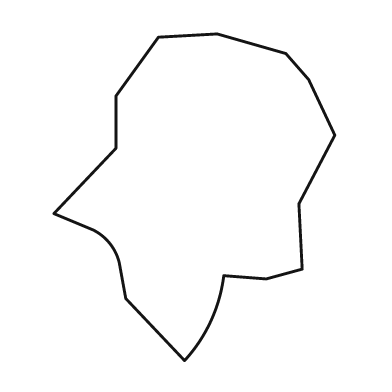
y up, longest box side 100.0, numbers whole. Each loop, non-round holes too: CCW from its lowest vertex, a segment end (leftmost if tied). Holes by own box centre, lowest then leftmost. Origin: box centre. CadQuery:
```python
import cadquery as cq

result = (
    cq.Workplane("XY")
    .moveTo(-3.0, -50.0)
    .threePointArc((5.0, -38.0), (9.0, -24.0))
    .lineTo(22.0, -25.0)
    .lineTo(33.0, -22.0)
    .lineTo(32.0, -2.0)
    .lineTo(43.0, 19.0)
    .lineTo(35.0, 36.0)
    .lineTo(28.0, 44.0)
    .lineTo(7.0, 50.0)
    .lineTo(-11.0, 49.0)
    .lineTo(-24.0, 31.0)
    .lineTo(-24.0, 15.0)
    .lineTo(-43.0, -5.0)
    .lineTo(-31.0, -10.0)
    .threePointArc((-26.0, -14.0), (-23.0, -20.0))
    .lineTo(-21.0, -31.0)
    .close()
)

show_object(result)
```